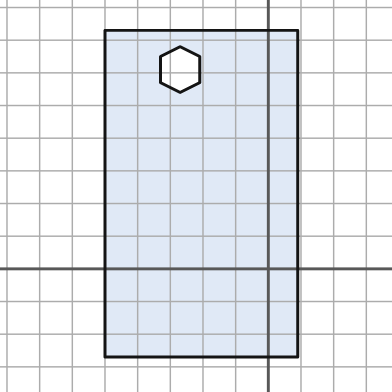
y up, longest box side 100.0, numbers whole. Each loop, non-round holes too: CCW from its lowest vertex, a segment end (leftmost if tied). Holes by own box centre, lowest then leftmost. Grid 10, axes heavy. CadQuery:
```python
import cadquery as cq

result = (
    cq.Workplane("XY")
    .moveTo(-50.0, -27.0)
    .lineTo(9.0, -27.0)
    .lineTo(9.0, 73.0)
    .lineTo(-50.0, 73.0)
    .close()
    .moveTo(-27.0, 54.0)
    .lineTo(-21.0, 57.0)
    .lineTo(-21.0, 65.0)
    .lineTo(-27.0, 68.0)
    .lineTo(-33.0, 65.0)
    .lineTo(-33.0, 57.0)
    .close()
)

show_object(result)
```